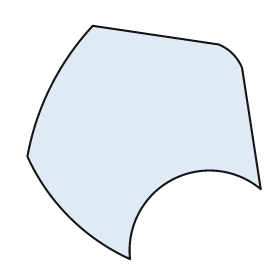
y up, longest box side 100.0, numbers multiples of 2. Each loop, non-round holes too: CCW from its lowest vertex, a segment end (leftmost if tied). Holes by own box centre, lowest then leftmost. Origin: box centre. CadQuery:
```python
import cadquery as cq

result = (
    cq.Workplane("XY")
    .moveTo(-6.0, -50.0)
    .threePointArc((12.0, -16.0), (50.0, -20.0))
    .lineTo(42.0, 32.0)
    .threePointArc((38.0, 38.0), (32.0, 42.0))
    .lineTo(-22.0, 50.0)
    .threePointArc((-40.0, 24.0), (-50.0, -6.0))
    .threePointArc((-32.0, -32.0), (-6.0, -50.0))
    .close()
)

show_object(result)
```